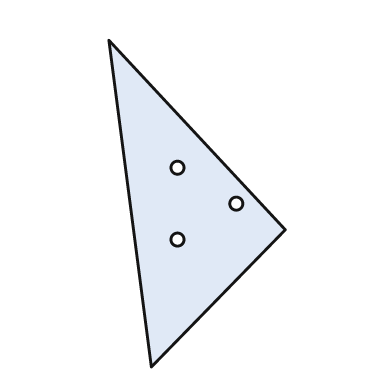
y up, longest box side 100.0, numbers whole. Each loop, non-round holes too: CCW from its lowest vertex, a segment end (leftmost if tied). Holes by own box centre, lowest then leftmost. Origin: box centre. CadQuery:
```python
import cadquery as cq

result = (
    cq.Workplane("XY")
    .moveTo(-14.0, -50.0)
    .lineTo(27.0, -8.0)
    .lineTo(-27.0, 50.0)
    .close()
    .moveTo(-6.0, -11.0)
    .circle(2.0)
    .moveTo(12.0, 0.0)
    .circle(2.0)
    .moveTo(-6.0, 11.0)
    .circle(2.0)
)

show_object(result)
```